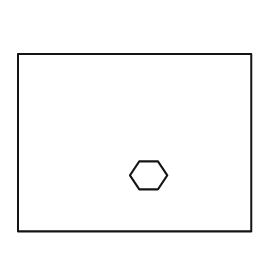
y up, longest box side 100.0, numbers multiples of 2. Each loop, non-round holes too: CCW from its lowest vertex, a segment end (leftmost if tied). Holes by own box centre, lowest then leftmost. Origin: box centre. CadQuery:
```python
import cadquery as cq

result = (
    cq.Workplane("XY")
    .moveTo(-50.0, -38.0)
    .lineTo(50.0, -38.0)
    .lineTo(50.0, 38.0)
    .lineTo(-50.0, 38.0)
    .close()
    .moveTo(2.0, -20.0)
    .lineTo(10.0, -20.0)
    .lineTo(14.0, -14.0)
    .lineTo(10.0, -8.0)
    .lineTo(2.0, -8.0)
    .lineTo(-2.0, -14.0)
    .close()
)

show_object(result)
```